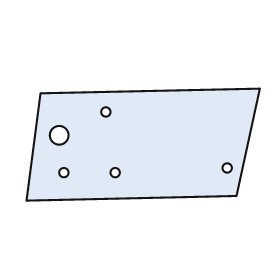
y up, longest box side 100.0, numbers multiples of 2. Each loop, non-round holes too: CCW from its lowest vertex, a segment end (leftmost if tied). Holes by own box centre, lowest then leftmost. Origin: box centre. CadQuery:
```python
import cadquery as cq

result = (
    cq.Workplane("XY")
    .moveTo(-50.0, -24.0)
    .lineTo(40.0, -22.0)
    .lineTo(50.0, 24.0)
    .lineTo(-44.0, 22.0)
    .close()
    .moveTo(-34.0, -12.0)
    .circle(2.0)
    .moveTo(-12.0, -12.0)
    .circle(2.0)
    .moveTo(36.0, -10.0)
    .circle(2.0)
    .moveTo(-36.0, 4.0)
    .circle(4.0)
    .moveTo(-16.0, 14.0)
    .circle(2.0)
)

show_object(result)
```